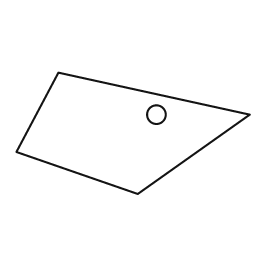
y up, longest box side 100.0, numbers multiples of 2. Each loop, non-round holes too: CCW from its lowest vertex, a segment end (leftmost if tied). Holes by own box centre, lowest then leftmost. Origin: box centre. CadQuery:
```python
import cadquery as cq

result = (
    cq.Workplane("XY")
    .moveTo(2.0, -26.0)
    .lineTo(50.0, 8.0)
    .lineTo(-32.0, 26.0)
    .lineTo(-50.0, -8.0)
    .close()
    .moveTo(10.0, 8.0)
    .circle(4.0)
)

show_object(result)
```